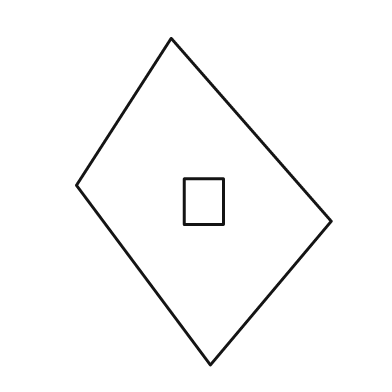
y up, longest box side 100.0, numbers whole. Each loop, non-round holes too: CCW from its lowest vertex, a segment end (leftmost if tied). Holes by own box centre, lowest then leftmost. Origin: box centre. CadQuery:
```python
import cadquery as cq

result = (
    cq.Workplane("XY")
    .moveTo(2.0, -50.0)
    .lineTo(39.0, -6.0)
    .lineTo(-10.0, 50.0)
    .lineTo(-39.0, 5.0)
    .close()
    .moveTo(-6.0, -7.0)
    .lineTo(6.0, -7.0)
    .lineTo(6.0, 7.0)
    .lineTo(-6.0, 7.0)
    .close()
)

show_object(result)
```